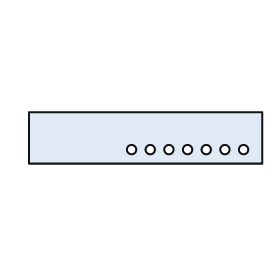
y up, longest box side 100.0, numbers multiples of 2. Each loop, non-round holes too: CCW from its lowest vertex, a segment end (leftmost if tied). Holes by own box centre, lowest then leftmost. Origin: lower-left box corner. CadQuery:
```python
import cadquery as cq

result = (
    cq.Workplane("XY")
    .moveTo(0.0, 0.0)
    .lineTo(100.0, 0.0)
    .lineTo(100.0, 22.0)
    .lineTo(0.0, 22.0)
    .close()
    .moveTo(44.0, 6.0)
    .circle(2.0)
    .moveTo(52.0, 6.0)
    .circle(2.0)
    .moveTo(60.0, 6.0)
    .circle(2.0)
    .moveTo(68.0, 6.0)
    .circle(2.0)
    .moveTo(76.0, 6.0)
    .circle(2.0)
    .moveTo(84.0, 6.0)
    .circle(2.0)
    .moveTo(92.0, 6.0)
    .circle(2.0)
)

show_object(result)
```